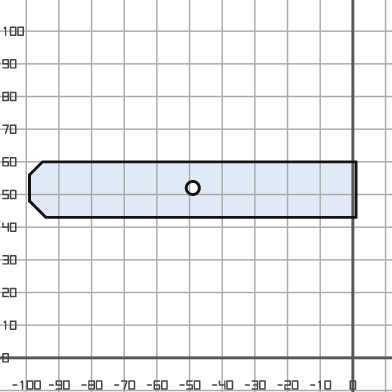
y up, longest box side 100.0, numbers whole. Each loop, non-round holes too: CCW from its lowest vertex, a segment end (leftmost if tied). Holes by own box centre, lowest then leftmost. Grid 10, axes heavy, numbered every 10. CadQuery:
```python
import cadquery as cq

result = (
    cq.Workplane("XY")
    .moveTo(-94.0, 43.0)
    .lineTo(1.0, 43.0)
    .lineTo(1.0, 60.0)
    .lineTo(-95.0, 60.0)
    .lineTo(-99.0, 56.0)
    .lineTo(-99.0, 48.0)
    .close()
    .moveTo(-49.0, 52.0)
    .circle(2.0)
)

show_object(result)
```